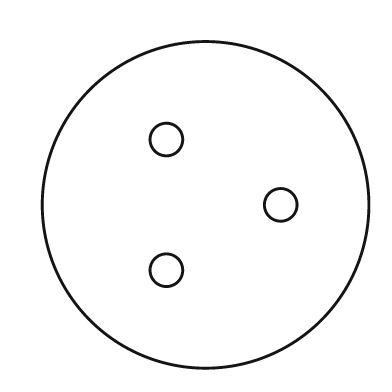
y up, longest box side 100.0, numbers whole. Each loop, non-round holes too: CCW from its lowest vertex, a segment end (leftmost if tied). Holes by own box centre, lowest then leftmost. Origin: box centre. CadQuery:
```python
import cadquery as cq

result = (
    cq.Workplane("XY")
    .moveTo(0.0, 0.0)
    .circle(50.0)
    .moveTo(-12.0, -20.0)
    .circle(5.0)
    .moveTo(23.0, 0.0)
    .circle(5.0)
    .moveTo(-12.0, 20.0)
    .circle(5.0)
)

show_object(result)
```